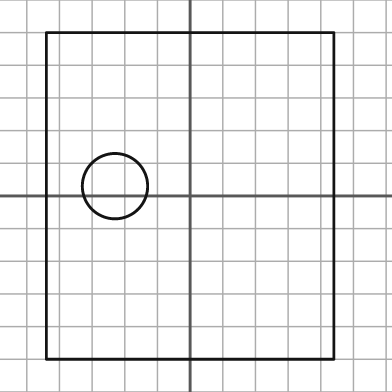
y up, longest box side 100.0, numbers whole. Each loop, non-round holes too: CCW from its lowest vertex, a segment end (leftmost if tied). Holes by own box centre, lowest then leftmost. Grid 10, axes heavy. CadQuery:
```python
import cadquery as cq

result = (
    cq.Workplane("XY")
    .moveTo(-44.0, -50.0)
    .lineTo(44.0, -50.0)
    .lineTo(44.0, 50.0)
    .lineTo(-44.0, 50.0)
    .close()
    .moveTo(-23.0, 3.0)
    .circle(10.0)
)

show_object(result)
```